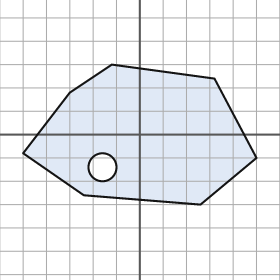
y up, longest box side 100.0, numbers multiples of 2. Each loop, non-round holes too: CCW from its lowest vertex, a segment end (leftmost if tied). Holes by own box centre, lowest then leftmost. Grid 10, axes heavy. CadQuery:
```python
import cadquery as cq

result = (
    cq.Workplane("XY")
    .moveTo(26.0, -30.0)
    .lineTo(50.0, -10.0)
    .lineTo(32.0, 24.0)
    .lineTo(-12.0, 30.0)
    .lineTo(-30.0, 18.0)
    .lineTo(-50.0, -8.0)
    .lineTo(-24.0, -26.0)
    .close()
    .moveTo(-16.0, -14.0)
    .circle(6.0)
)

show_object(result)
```